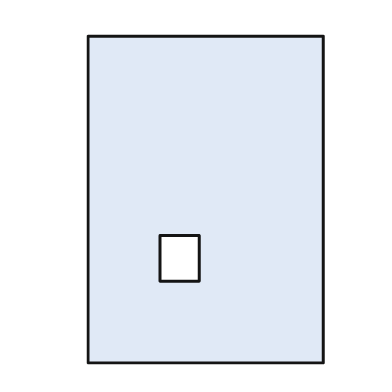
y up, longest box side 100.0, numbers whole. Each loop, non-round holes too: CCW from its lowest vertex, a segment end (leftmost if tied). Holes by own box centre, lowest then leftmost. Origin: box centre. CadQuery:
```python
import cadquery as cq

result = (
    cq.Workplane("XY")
    .moveTo(-36.0, -50.0)
    .lineTo(36.0, -50.0)
    .lineTo(36.0, 50.0)
    .lineTo(-36.0, 50.0)
    .close()
    .moveTo(-14.0, -25.0)
    .lineTo(-2.0, -25.0)
    .lineTo(-2.0, -11.0)
    .lineTo(-14.0, -11.0)
    .close()
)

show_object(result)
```